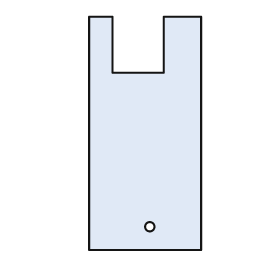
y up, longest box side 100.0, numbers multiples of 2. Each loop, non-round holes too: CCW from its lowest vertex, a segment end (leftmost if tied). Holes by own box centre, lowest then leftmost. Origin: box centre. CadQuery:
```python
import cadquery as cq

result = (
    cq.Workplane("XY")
    .moveTo(-24.0, -50.0)
    .lineTo(24.0, -50.0)
    .lineTo(24.0, 50.0)
    .lineTo(8.0, 50.0)
    .lineTo(8.0, 26.0)
    .lineTo(-14.0, 26.0)
    .lineTo(-14.0, 50.0)
    .lineTo(-24.0, 50.0)
    .close()
    .moveTo(2.0, -40.0)
    .circle(2.0)
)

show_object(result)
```